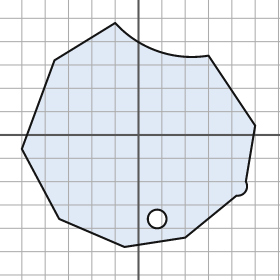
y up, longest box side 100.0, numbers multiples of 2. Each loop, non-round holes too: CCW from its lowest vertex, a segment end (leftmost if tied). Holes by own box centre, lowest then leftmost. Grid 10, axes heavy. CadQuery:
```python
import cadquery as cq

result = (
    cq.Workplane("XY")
    .moveTo(-6.0, -48.0)
    .lineTo(20.0, -44.0)
    .lineTo(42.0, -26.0)
    .threePointArc((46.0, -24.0), (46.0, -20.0))
    .lineTo(50.0, 4.0)
    .lineTo(30.0, 34.0)
    .threePointArc((8.0, 36.0), (-10.0, 48.0))
    .lineTo(-36.0, 32.0)
    .lineTo(-50.0, -6.0)
    .lineTo(-34.0, -36.0)
    .close()
    .moveTo(8.0, -36.0)
    .circle(4.0)
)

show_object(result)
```